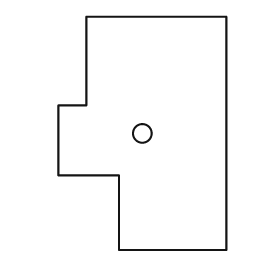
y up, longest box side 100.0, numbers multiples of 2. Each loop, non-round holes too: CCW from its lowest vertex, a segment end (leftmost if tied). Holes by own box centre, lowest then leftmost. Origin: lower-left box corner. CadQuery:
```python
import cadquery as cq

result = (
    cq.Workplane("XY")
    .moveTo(26.0, 0.0)
    .lineTo(72.0, 0.0)
    .lineTo(72.0, 100.0)
    .lineTo(12.0, 100.0)
    .lineTo(12.0, 62.0)
    .lineTo(0.0, 62.0)
    .lineTo(0.0, 32.0)
    .lineTo(26.0, 32.0)
    .close()
    .moveTo(36.0, 50.0)
    .circle(4.0)
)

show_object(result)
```